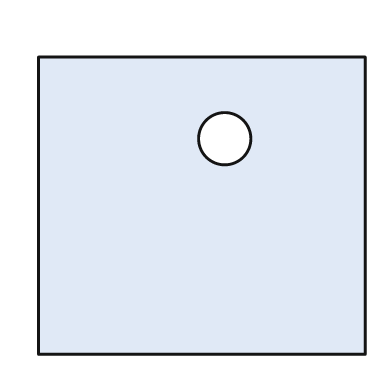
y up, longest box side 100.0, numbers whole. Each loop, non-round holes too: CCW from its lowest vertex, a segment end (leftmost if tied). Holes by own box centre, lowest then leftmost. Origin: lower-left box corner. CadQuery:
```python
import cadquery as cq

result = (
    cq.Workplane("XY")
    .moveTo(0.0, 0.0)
    .lineTo(100.0, 0.0)
    .lineTo(100.0, 91.0)
    .lineTo(0.0, 91.0)
    .close()
    .moveTo(57.0, 66.0)
    .circle(8.0)
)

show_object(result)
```